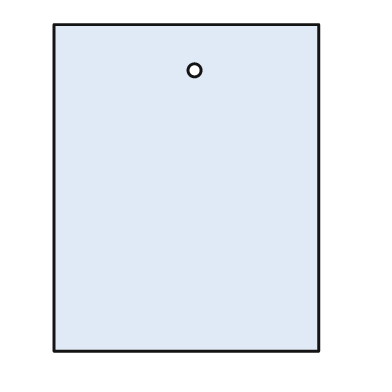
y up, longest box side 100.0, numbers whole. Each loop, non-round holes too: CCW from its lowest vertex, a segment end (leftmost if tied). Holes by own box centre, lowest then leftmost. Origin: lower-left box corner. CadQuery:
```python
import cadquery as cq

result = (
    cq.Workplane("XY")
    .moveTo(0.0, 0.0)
    .lineTo(81.0, 0.0)
    .lineTo(81.0, 100.0)
    .lineTo(0.0, 100.0)
    .close()
    .moveTo(43.0, 86.0)
    .circle(2.0)
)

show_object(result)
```